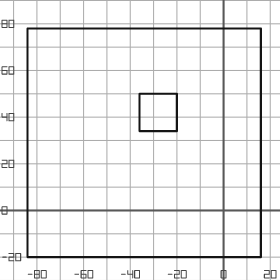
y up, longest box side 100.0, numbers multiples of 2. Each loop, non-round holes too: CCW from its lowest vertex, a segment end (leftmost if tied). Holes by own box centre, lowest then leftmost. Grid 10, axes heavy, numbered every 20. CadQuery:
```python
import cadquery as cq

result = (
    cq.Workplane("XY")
    .moveTo(-84.0, -20.0)
    .lineTo(16.0, -20.0)
    .lineTo(16.0, 78.0)
    .lineTo(-84.0, 78.0)
    .close()
    .moveTo(-36.0, 34.0)
    .lineTo(-20.0, 34.0)
    .lineTo(-20.0, 50.0)
    .lineTo(-36.0, 50.0)
    .close()
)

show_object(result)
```